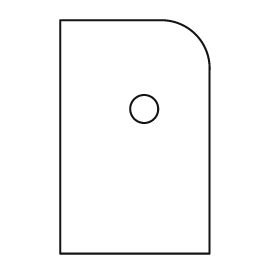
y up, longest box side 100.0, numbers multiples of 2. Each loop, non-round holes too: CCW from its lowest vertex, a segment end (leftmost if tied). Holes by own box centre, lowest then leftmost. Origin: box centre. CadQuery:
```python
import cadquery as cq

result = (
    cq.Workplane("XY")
    .moveTo(-32.0, -50.0)
    .lineTo(32.0, -50.0)
    .lineTo(32.0, 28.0)
    .threePointArc((26.0, 44.0), (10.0, 50.0))
    .lineTo(-32.0, 50.0)
    .close()
    .moveTo(4.0, 12.0)
    .circle(6.0)
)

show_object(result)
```